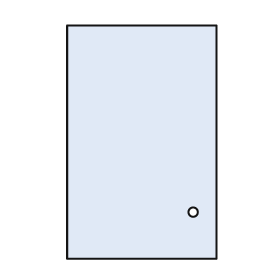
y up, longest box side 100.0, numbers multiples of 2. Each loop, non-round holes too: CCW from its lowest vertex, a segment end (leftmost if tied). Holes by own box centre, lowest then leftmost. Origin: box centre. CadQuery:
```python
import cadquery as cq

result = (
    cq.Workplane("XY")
    .moveTo(-32.0, -50.0)
    .lineTo(32.0, -50.0)
    .lineTo(32.0, 50.0)
    .lineTo(-32.0, 50.0)
    .close()
    .moveTo(22.0, -30.0)
    .circle(2.0)
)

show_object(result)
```